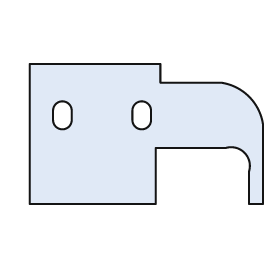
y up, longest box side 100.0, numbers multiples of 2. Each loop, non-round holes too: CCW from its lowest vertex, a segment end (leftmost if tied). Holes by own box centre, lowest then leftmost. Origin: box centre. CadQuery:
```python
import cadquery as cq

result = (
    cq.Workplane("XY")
    .moveTo(-50.0, -30.0)
    .lineTo(4.0, -30.0)
    .lineTo(4.0, -6.0)
    .lineTo(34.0, -6.0)
    .threePointArc((42.0, -8.0), (44.0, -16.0))
    .lineTo(44.0, -30.0)
    .lineTo(50.0, -30.0)
    .lineTo(50.0, 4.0)
    .threePointArc((44.0, 16.0), (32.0, 22.0))
    .lineTo(6.0, 22.0)
    .lineTo(6.0, 30.0)
    .lineTo(-50.0, 30.0)
    .close()
    .moveTo(-40.0, 6.0)
    .threePointArc((-36.0, 2.0), (-32.0, 6.0))
    .lineTo(-32.0, 10.0)
    .threePointArc((-36.0, 14.0), (-40.0, 10.0))
    .close()
    .moveTo(-6.0, 6.0)
    .threePointArc((-2.0, 2.0), (2.0, 6.0))
    .lineTo(2.0, 10.0)
    .threePointArc((-2.0, 14.0), (-6.0, 10.0))
    .close()
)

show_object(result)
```